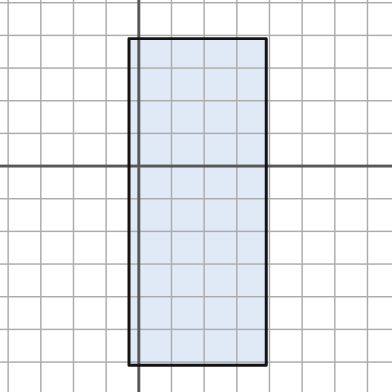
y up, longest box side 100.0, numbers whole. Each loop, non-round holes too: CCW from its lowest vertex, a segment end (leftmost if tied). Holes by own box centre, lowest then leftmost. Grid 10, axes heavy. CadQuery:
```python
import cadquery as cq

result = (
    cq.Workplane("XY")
    .moveTo(-3.0, -61.0)
    .lineTo(39.0, -61.0)
    .lineTo(39.0, 39.0)
    .lineTo(-3.0, 39.0)
    .close()
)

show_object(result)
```